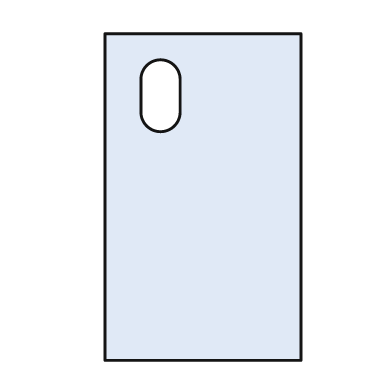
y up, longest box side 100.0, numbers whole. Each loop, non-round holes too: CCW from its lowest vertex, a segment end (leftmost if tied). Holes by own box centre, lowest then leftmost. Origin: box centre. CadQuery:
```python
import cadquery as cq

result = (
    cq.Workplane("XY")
    .moveTo(-30.0, -50.0)
    .lineTo(30.0, -50.0)
    .lineTo(30.0, 50.0)
    .lineTo(-30.0, 50.0)
    .close()
    .moveTo(-19.0, 26.0)
    .threePointArc((-13.0, 20.0), (-7.0, 26.0))
    .lineTo(-7.0, 36.0)
    .threePointArc((-13.0, 42.0), (-19.0, 36.0))
    .close()
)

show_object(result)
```